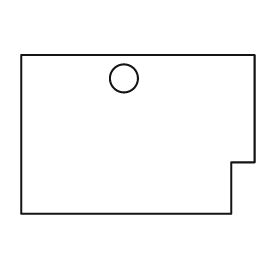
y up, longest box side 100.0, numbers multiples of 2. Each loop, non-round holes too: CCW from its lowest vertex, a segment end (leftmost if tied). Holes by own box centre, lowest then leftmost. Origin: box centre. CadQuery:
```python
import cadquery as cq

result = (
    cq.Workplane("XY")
    .moveTo(-50.0, -34.0)
    .lineTo(40.0, -34.0)
    .lineTo(40.0, -12.0)
    .lineTo(50.0, -12.0)
    .lineTo(50.0, 34.0)
    .lineTo(-50.0, 34.0)
    .close()
    .moveTo(-6.0, 24.0)
    .circle(6.0)
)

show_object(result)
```